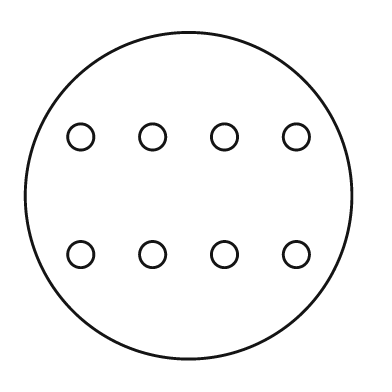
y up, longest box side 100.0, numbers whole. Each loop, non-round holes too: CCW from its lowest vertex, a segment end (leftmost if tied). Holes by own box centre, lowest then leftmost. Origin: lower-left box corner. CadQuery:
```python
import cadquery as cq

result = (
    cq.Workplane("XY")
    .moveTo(50.0, 50.0)
    .circle(50.0)
    .moveTo(17.0, 32.0)
    .circle(4.0)
    .moveTo(39.0, 32.0)
    .circle(4.0)
    .moveTo(61.0, 32.0)
    .circle(4.0)
    .moveTo(83.0, 32.0)
    .circle(4.0)
    .moveTo(17.0, 68.0)
    .circle(4.0)
    .moveTo(39.0, 68.0)
    .circle(4.0)
    .moveTo(61.0, 68.0)
    .circle(4.0)
    .moveTo(83.0, 68.0)
    .circle(4.0)
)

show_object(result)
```